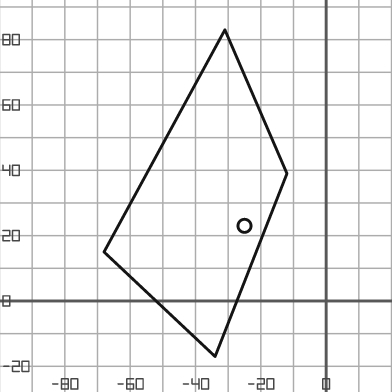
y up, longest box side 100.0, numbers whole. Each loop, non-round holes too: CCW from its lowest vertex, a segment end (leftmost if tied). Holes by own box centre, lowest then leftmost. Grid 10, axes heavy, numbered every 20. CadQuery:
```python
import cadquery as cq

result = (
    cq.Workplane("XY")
    .moveTo(-34.0, -17.0)
    .lineTo(-12.0, 39.0)
    .lineTo(-31.0, 83.0)
    .lineTo(-68.0, 15.0)
    .close()
    .moveTo(-25.0, 23.0)
    .circle(2.0)
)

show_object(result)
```